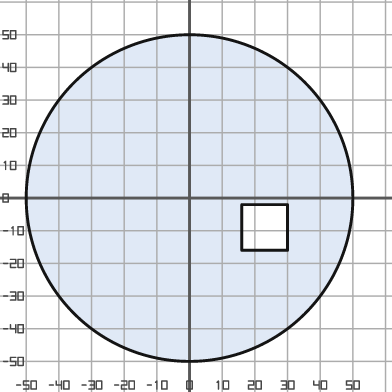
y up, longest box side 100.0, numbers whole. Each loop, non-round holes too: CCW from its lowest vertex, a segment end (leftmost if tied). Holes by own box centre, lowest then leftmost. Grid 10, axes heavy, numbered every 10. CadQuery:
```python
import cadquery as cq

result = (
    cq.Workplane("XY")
    .moveTo(0.0, 0.0)
    .circle(50.0)
    .moveTo(16.0, -16.0)
    .lineTo(30.0, -16.0)
    .lineTo(30.0, -2.0)
    .lineTo(16.0, -2.0)
    .close()
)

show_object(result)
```